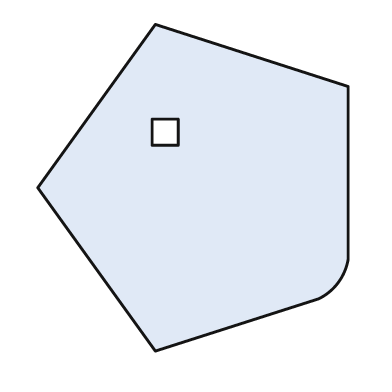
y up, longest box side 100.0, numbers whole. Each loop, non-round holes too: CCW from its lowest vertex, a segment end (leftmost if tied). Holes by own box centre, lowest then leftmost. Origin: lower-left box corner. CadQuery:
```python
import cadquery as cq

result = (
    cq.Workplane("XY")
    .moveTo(36.0, 0.0)
    .lineTo(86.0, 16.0)
    .threePointArc((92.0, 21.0), (95.0, 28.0))
    .lineTo(95.0, 81.0)
    .lineTo(36.0, 100.0)
    .lineTo(0.0, 50.0)
    .close()
    .moveTo(35.0, 63.0)
    .lineTo(43.0, 63.0)
    .lineTo(43.0, 71.0)
    .lineTo(35.0, 71.0)
    .close()
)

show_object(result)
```